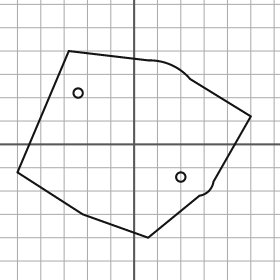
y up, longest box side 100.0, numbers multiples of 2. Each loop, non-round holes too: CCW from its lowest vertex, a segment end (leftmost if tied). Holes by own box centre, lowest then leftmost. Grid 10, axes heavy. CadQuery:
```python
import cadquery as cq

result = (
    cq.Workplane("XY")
    .moveTo(6.0, -40.0)
    .lineTo(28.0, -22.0)
    .threePointArc((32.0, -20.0), (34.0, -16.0))
    .lineTo(50.0, 12.0)
    .lineTo(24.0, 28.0)
    .threePointArc((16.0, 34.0), (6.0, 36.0))
    .lineTo(-28.0, 40.0)
    .lineTo(-50.0, -12.0)
    .lineTo(-22.0, -30.0)
    .close()
    .moveTo(20.0, -14.0)
    .circle(2.0)
    .moveTo(-24.0, 22.0)
    .circle(2.0)
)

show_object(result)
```